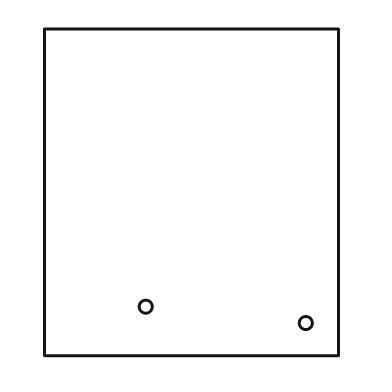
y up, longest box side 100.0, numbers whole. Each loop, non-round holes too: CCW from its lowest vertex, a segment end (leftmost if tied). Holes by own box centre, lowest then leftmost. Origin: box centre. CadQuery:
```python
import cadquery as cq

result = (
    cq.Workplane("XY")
    .moveTo(-45.0, -50.0)
    .lineTo(45.0, -50.0)
    .lineTo(45.0, 50.0)
    .lineTo(-45.0, 50.0)
    .close()
    .moveTo(35.0, -40.0)
    .circle(2.0)
    .moveTo(-14.0, -35.0)
    .circle(2.0)
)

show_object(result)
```